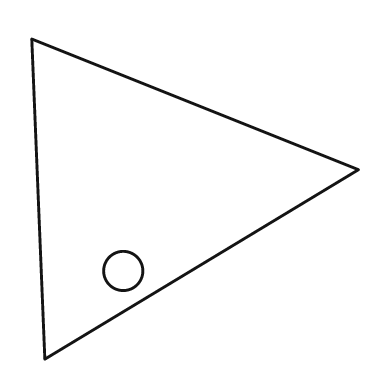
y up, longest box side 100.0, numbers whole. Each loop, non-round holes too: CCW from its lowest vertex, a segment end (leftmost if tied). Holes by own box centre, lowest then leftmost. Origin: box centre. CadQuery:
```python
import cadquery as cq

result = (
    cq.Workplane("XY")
    .moveTo(-46.0, -49.0)
    .lineTo(50.0, 9.0)
    .lineTo(-50.0, 49.0)
    .close()
    .moveTo(-22.0, -22.0)
    .circle(6.0)
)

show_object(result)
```